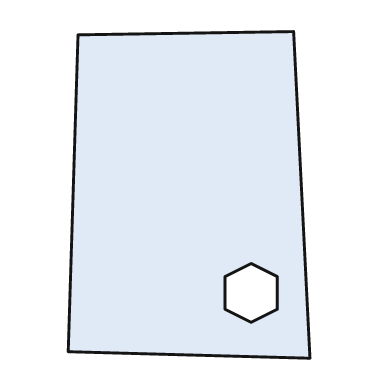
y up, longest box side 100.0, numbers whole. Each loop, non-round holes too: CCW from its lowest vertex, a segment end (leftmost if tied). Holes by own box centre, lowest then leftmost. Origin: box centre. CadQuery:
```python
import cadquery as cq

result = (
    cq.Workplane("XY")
    .moveTo(37.0, -50.0)
    .lineTo(32.0, 50.0)
    .lineTo(-34.0, 49.0)
    .lineTo(-37.0, -48.0)
    .close()
    .moveTo(19.0, -39.0)
    .lineTo(27.0, -35.0)
    .lineTo(27.0, -25.0)
    .lineTo(19.0, -21.0)
    .lineTo(11.0, -25.0)
    .lineTo(11.0, -35.0)
    .close()
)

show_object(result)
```